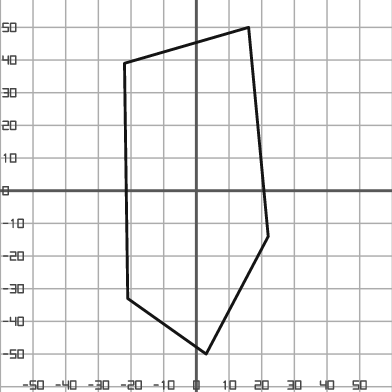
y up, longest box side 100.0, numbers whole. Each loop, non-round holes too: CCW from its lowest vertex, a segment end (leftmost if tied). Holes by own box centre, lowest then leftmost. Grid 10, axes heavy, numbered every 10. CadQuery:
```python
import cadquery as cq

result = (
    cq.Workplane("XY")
    .moveTo(3.0, -50.0)
    .lineTo(22.0, -14.0)
    .lineTo(16.0, 50.0)
    .lineTo(-22.0, 39.0)
    .lineTo(-21.0, -33.0)
    .close()
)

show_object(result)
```